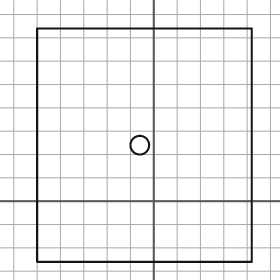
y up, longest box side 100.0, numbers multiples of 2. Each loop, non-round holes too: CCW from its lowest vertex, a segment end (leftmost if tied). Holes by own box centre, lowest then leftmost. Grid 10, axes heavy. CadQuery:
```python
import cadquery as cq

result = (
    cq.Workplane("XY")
    .moveTo(-50.0, -26.0)
    .lineTo(42.0, -26.0)
    .lineTo(42.0, 74.0)
    .lineTo(-50.0, 74.0)
    .close()
    .moveTo(-6.0, 24.0)
    .circle(4.0)
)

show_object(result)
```